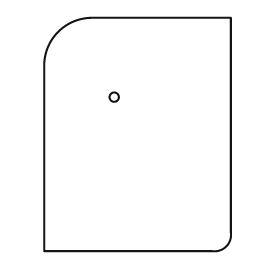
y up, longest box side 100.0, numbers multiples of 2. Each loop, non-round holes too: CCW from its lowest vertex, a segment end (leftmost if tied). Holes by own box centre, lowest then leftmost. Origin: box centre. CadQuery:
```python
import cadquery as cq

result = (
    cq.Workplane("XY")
    .moveTo(-40.0, -50.0)
    .lineTo(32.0, -50.0)
    .threePointArc((38.0, -48.0), (40.0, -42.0))
    .lineTo(40.0, 50.0)
    .lineTo(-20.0, 50.0)
    .threePointArc((-34.0, 44.0), (-40.0, 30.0))
    .close()
    .moveTo(-10.0, 16.0)
    .circle(2.0)
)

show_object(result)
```